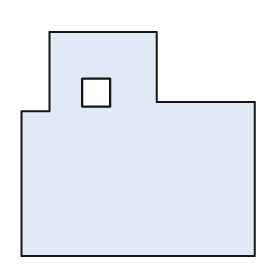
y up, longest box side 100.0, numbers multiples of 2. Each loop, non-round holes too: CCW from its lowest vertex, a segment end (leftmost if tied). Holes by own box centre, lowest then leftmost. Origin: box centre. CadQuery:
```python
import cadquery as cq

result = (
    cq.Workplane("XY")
    .moveTo(-50.0, -48.0)
    .lineTo(50.0, -48.0)
    .lineTo(50.0, 18.0)
    .lineTo(8.0, 18.0)
    .lineTo(8.0, 48.0)
    .lineTo(-38.0, 48.0)
    .lineTo(-38.0, 14.0)
    .lineTo(-50.0, 14.0)
    .close()
    .moveTo(-24.0, 16.0)
    .lineTo(-12.0, 16.0)
    .lineTo(-12.0, 28.0)
    .lineTo(-24.0, 28.0)
    .close()
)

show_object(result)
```